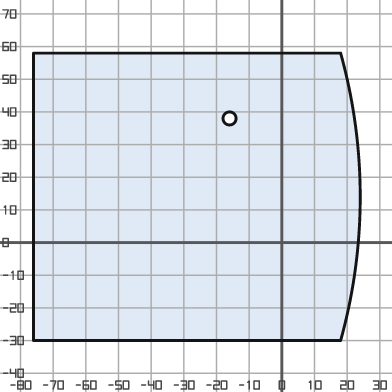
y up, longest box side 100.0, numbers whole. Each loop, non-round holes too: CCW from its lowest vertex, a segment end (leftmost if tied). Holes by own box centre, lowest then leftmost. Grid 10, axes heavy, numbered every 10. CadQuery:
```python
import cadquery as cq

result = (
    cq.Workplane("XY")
    .moveTo(-76.0, -30.0)
    .lineTo(18.0, -30.0)
    .threePointArc((24.0, 14.0), (18.0, 58.0))
    .lineTo(-76.0, 58.0)
    .close()
    .moveTo(-16.0, 38.0)
    .circle(2.0)
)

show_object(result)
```